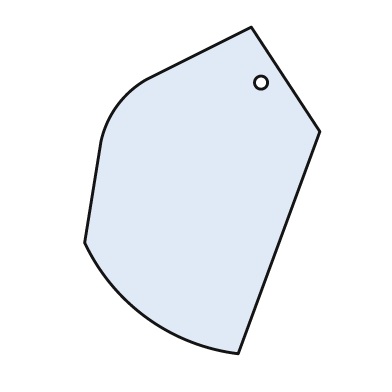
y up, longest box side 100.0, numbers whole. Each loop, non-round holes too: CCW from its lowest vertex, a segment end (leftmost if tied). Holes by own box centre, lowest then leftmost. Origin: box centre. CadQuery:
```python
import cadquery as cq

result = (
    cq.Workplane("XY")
    .moveTo(11.0, -50.0)
    .lineTo(36.0, 18.0)
    .lineTo(15.0, 50.0)
    .lineTo(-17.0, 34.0)
    .threePointArc((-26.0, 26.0), (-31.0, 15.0))
    .lineTo(-36.0, -16.0)
    .threePointArc((-17.0, -39.0), (11.0, -50.0))
    .close()
    .moveTo(18.0, 33.0)
    .circle(2.0)
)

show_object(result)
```